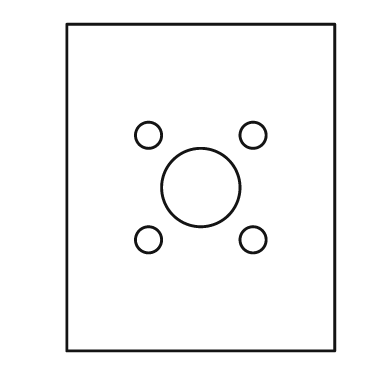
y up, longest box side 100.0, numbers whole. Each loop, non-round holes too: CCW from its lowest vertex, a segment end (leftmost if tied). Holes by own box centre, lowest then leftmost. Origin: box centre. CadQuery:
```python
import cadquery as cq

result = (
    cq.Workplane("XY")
    .moveTo(-41.0, -50.0)
    .lineTo(41.0, -50.0)
    .lineTo(41.0, 50.0)
    .lineTo(-41.0, 50.0)
    .close()
    .moveTo(-16.0, -16.0)
    .circle(4.0)
    .moveTo(16.0, -16.0)
    .circle(4.0)
    .moveTo(0.0, 0.0)
    .circle(12.0)
    .moveTo(-16.0, 16.0)
    .circle(4.0)
    .moveTo(16.0, 16.0)
    .circle(4.0)
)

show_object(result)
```